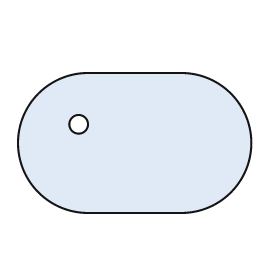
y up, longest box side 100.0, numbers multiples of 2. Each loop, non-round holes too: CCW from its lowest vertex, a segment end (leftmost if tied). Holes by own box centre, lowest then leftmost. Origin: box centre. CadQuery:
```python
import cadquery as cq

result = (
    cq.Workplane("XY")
    .moveTo(-20.0, -30.0)
    .lineTo(20.0, -30.0)
    .threePointArc((50.0, 0.0), (20.0, 30.0))
    .lineTo(-20.0, 30.0)
    .threePointArc((-50.0, 0.0), (-20.0, -30.0))
    .close()
    .moveTo(-24.0, 8.0)
    .circle(4.0)
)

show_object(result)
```